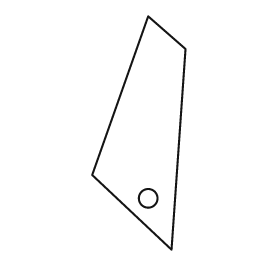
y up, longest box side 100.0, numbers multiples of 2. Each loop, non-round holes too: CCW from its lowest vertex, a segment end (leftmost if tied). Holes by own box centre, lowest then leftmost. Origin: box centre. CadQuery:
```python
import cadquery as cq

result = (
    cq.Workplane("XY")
    .moveTo(14.0, -50.0)
    .lineTo(20.0, 36.0)
    .lineTo(4.0, 50.0)
    .lineTo(-20.0, -18.0)
    .close()
    .moveTo(4.0, -28.0)
    .circle(4.0)
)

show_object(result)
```